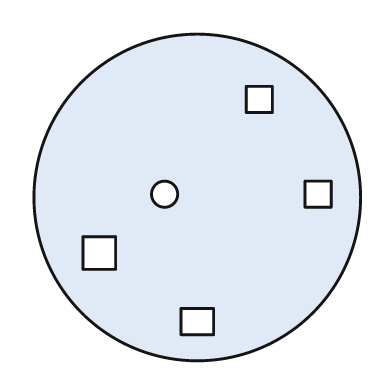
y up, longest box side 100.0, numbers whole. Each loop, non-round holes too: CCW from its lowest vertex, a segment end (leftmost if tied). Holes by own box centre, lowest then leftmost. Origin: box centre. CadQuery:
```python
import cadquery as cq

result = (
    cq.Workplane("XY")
    .moveTo(0.0, 0.0)
    .circle(50.0)
    .moveTo(-5.0, -42.0)
    .lineTo(5.0, -42.0)
    .lineTo(5.0, -34.0)
    .lineTo(-5.0, -34.0)
    .close()
    .moveTo(-35.0, -22.0)
    .lineTo(-25.0, -22.0)
    .lineTo(-25.0, -12.0)
    .lineTo(-35.0, -12.0)
    .close()
    .moveTo(-10.0, 1.0)
    .circle(4.0)
    .moveTo(33.0, -3.0)
    .lineTo(41.0, -3.0)
    .lineTo(41.0, 5.0)
    .lineTo(33.0, 5.0)
    .close()
    .moveTo(15.0, 26.0)
    .lineTo(23.0, 26.0)
    .lineTo(23.0, 34.0)
    .lineTo(15.0, 34.0)
    .close()
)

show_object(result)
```